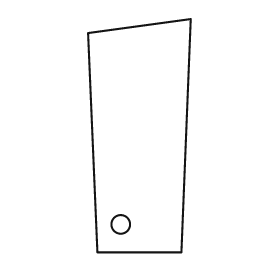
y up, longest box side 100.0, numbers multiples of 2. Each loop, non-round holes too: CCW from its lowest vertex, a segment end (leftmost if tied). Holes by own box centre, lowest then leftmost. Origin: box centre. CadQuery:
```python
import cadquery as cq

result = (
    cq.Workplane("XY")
    .moveTo(-18.0, -50.0)
    .lineTo(18.0, -50.0)
    .lineTo(22.0, 50.0)
    .lineTo(-22.0, 44.0)
    .close()
    .moveTo(-8.0, -38.0)
    .circle(4.0)
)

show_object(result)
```